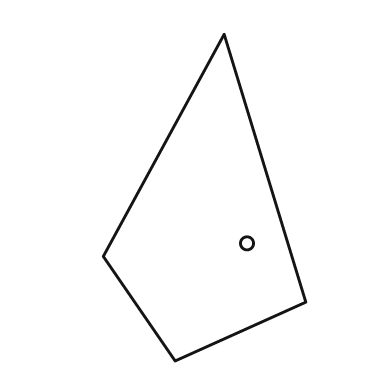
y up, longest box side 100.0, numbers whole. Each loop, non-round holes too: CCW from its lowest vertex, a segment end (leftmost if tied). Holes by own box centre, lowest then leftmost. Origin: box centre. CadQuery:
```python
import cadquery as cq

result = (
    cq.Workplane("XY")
    .moveTo(-9.0, -50.0)
    .lineTo(31.0, -32.0)
    .lineTo(6.0, 50.0)
    .lineTo(-31.0, -18.0)
    .close()
    .moveTo(13.0, -14.0)
    .circle(2.0)
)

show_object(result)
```